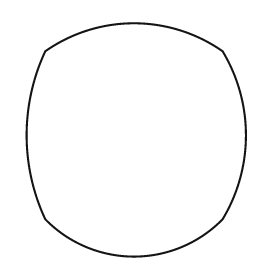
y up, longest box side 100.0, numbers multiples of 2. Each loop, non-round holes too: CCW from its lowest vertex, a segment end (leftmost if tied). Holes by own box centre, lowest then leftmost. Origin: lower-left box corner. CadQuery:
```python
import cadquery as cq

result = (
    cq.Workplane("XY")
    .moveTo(8.0, 16.0)
    .threePointArc((46.0, 0.0), (84.0, 16.0))
    .threePointArc((94.0, 52.0), (84.0, 88.0))
    .threePointArc((46.0, 100.0), (8.0, 88.0))
    .threePointArc((0.0, 52.0), (8.0, 16.0))
    .close()
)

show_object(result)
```